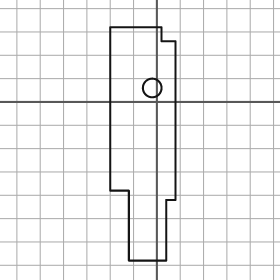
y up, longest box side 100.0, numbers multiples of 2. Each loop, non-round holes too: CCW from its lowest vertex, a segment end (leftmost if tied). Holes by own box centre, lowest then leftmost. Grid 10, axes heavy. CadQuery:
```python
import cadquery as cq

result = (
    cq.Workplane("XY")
    .moveTo(-12.0, -68.0)
    .lineTo(4.0, -68.0)
    .lineTo(4.0, -42.0)
    .lineTo(8.0, -42.0)
    .lineTo(8.0, 26.0)
    .lineTo(2.0, 26.0)
    .lineTo(2.0, 32.0)
    .lineTo(-20.0, 32.0)
    .lineTo(-20.0, -38.0)
    .lineTo(-12.0, -38.0)
    .close()
    .moveTo(-2.0, 6.0)
    .circle(4.0)
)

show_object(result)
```